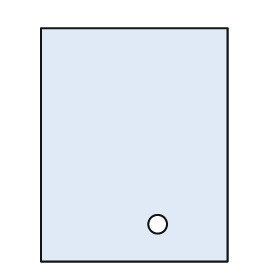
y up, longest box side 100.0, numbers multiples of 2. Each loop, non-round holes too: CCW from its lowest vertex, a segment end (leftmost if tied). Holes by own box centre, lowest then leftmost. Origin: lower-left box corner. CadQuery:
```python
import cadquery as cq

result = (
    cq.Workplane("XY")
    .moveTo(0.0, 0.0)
    .lineTo(80.0, 0.0)
    .lineTo(80.0, 100.0)
    .lineTo(0.0, 100.0)
    .close()
    .moveTo(50.0, 16.0)
    .circle(4.0)
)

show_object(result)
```